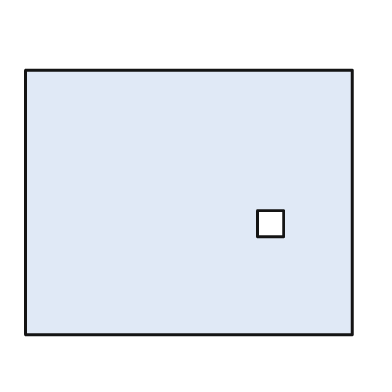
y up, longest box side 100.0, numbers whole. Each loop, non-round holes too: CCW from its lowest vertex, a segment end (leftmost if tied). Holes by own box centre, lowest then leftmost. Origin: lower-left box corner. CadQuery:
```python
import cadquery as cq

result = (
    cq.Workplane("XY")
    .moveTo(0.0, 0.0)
    .lineTo(100.0, 0.0)
    .lineTo(100.0, 81.0)
    .lineTo(0.0, 81.0)
    .close()
    .moveTo(71.0, 30.0)
    .lineTo(79.0, 30.0)
    .lineTo(79.0, 38.0)
    .lineTo(71.0, 38.0)
    .close()
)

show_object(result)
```